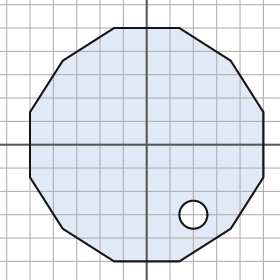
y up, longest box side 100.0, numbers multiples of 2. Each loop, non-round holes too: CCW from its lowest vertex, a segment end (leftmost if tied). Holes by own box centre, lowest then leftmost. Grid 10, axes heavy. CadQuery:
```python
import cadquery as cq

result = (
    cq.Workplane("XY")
    .moveTo(-14.0, -50.0)
    .lineTo(14.0, -50.0)
    .lineTo(36.0, -36.0)
    .lineTo(50.0, -14.0)
    .lineTo(50.0, 14.0)
    .lineTo(36.0, 36.0)
    .lineTo(14.0, 50.0)
    .lineTo(-14.0, 50.0)
    .lineTo(-36.0, 36.0)
    .lineTo(-50.0, 14.0)
    .lineTo(-50.0, -14.0)
    .lineTo(-36.0, -36.0)
    .close()
    .moveTo(20.0, -30.0)
    .circle(6.0)
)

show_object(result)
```